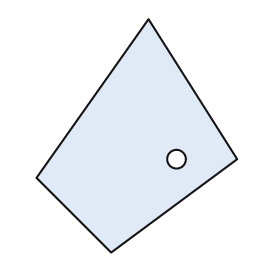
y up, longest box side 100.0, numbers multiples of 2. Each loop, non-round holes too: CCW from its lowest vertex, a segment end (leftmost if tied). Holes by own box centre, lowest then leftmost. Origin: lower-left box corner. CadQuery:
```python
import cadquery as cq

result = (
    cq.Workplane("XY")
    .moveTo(32.0, 0.0)
    .lineTo(86.0, 40.0)
    .lineTo(48.0, 100.0)
    .lineTo(0.0, 32.0)
    .close()
    .moveTo(60.0, 40.0)
    .circle(4.0)
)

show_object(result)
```